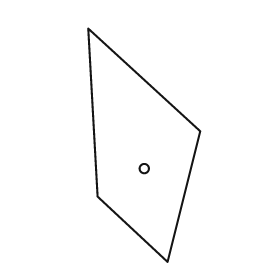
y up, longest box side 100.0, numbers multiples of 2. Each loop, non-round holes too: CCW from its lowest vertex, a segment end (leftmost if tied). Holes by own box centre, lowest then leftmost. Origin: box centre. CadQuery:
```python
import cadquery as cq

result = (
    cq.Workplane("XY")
    .moveTo(10.0, -50.0)
    .lineTo(24.0, 6.0)
    .lineTo(-24.0, 50.0)
    .lineTo(-20.0, -22.0)
    .close()
    .moveTo(0.0, -10.0)
    .circle(2.0)
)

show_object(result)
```